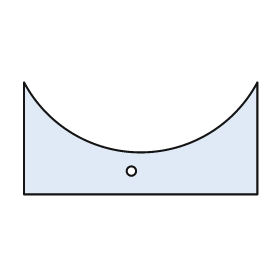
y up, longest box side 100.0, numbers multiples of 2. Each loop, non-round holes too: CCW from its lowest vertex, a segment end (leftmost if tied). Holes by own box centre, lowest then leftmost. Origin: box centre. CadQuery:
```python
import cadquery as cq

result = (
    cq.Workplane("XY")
    .moveTo(-50.0, -24.0)
    .lineTo(50.0, -24.0)
    .lineTo(50.0, 24.0)
    .threePointArc((0.0, -6.0), (-50.0, 24.0))
    .close()
    .moveTo(-4.0, -14.0)
    .circle(2.0)
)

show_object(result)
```